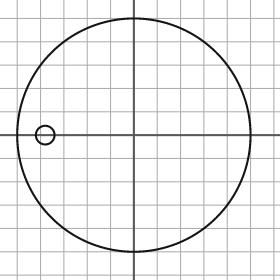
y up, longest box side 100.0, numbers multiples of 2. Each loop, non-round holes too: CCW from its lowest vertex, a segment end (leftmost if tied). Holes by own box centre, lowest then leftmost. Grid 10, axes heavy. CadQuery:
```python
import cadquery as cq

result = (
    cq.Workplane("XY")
    .moveTo(0.0, 0.0)
    .circle(50.0)
    .moveTo(-38.0, 0.0)
    .circle(4.0)
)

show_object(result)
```